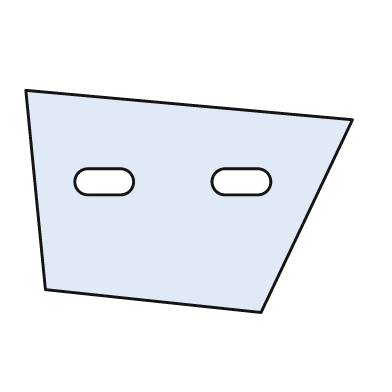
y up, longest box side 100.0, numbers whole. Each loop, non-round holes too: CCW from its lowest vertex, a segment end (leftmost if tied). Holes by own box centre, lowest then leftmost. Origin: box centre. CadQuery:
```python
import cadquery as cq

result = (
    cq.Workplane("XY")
    .moveTo(22.0, -34.0)
    .lineTo(50.0, 25.0)
    .lineTo(-50.0, 34.0)
    .lineTo(-44.0, -27.0)
    .close()
    .moveTo(-31.0, 2.0)
    .lineTo(-21.0, 2.0)
    .threePointArc((-17.0, 6.0), (-21.0, 10.0))
    .lineTo(-31.0, 10.0)
    .threePointArc((-35.0, 6.0), (-31.0, 2.0))
    .close()
    .moveTo(11.0, 2.0)
    .lineTo(21.0, 2.0)
    .threePointArc((25.0, 6.0), (21.0, 10.0))
    .lineTo(11.0, 10.0)
    .threePointArc((7.0, 6.0), (11.0, 2.0))
    .close()
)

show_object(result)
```